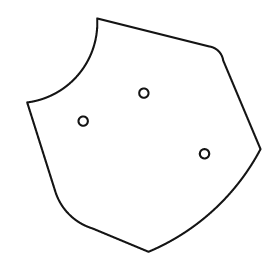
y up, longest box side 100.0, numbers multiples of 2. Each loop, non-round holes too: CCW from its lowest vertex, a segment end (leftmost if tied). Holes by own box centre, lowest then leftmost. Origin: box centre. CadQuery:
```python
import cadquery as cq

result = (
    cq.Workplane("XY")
    .moveTo(2.0, -50.0)
    .threePointArc((30.0, -32.0), (50.0, -6.0))
    .lineTo(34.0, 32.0)
    .threePointArc((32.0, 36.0), (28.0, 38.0))
    .lineTo(-20.0, 50.0)
    .threePointArc((-28.0, 26.0), (-50.0, 14.0))
    .lineTo(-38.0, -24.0)
    .threePointArc((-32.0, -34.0), (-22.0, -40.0))
    .close()
    .moveTo(26.0, -8.0)
    .circle(2.0)
    .moveTo(-26.0, 6.0)
    .circle(2.0)
    .moveTo(0.0, 18.0)
    .circle(2.0)
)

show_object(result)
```